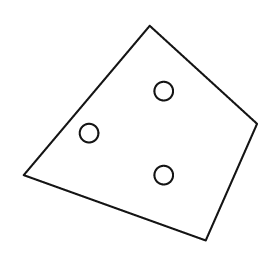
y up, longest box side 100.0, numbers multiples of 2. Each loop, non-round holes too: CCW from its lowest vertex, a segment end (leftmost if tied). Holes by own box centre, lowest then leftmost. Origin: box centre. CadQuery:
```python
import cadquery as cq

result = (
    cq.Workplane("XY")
    .moveTo(28.0, -46.0)
    .lineTo(50.0, 4.0)
    .lineTo(4.0, 46.0)
    .lineTo(-50.0, -18.0)
    .close()
    .moveTo(10.0, -18.0)
    .circle(4.0)
    .moveTo(-22.0, 0.0)
    .circle(4.0)
    .moveTo(10.0, 18.0)
    .circle(4.0)
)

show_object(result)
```